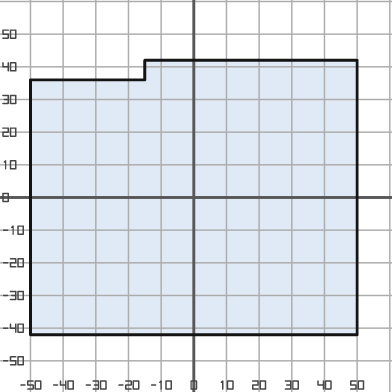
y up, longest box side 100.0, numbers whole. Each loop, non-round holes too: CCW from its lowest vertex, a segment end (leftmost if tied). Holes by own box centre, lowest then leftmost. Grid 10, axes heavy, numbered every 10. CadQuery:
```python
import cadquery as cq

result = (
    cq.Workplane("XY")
    .moveTo(-50.0, -42.0)
    .lineTo(50.0, -42.0)
    .lineTo(50.0, 42.0)
    .lineTo(-15.0, 42.0)
    .lineTo(-15.0, 36.0)
    .lineTo(-50.0, 36.0)
    .close()
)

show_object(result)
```